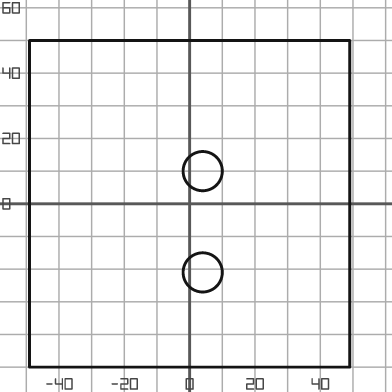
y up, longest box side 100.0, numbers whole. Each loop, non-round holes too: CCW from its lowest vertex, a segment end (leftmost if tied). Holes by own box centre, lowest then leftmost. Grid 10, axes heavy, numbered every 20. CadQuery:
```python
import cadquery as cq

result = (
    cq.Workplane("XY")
    .moveTo(-49.0, -50.0)
    .lineTo(49.0, -50.0)
    .lineTo(49.0, 50.0)
    .lineTo(-49.0, 50.0)
    .close()
    .moveTo(4.0, -21.0)
    .circle(6.0)
    .moveTo(4.0, 10.0)
    .circle(6.0)
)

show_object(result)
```